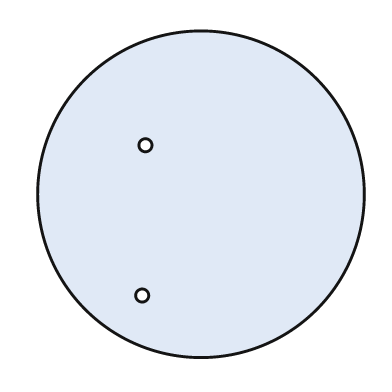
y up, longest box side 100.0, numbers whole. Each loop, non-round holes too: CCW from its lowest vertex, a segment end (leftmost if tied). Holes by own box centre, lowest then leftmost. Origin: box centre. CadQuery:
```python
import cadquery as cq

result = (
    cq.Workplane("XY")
    .moveTo(0.0, 0.0)
    .circle(50.0)
    .moveTo(-18.0, -31.0)
    .circle(2.0)
    .moveTo(-17.0, 15.0)
    .circle(2.0)
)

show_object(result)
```